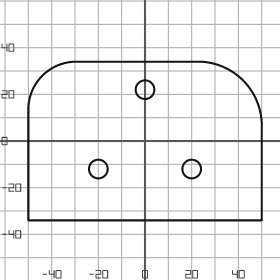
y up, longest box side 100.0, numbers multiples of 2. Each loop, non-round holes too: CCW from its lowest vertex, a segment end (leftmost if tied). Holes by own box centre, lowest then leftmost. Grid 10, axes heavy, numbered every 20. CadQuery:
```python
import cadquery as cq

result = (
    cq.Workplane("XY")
    .moveTo(-50.0, -34.0)
    .lineTo(50.0, -34.0)
    .lineTo(50.0, 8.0)
    .threePointArc((42.0, 26.0), (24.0, 34.0))
    .lineTo(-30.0, 34.0)
    .threePointArc((-44.0, 28.0), (-50.0, 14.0))
    .close()
    .moveTo(-20.0, -12.0)
    .circle(4.0)
    .moveTo(20.0, -12.0)
    .circle(4.0)
    .moveTo(0.0, 22.0)
    .circle(4.0)
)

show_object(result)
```